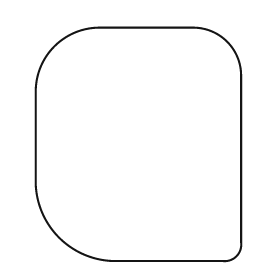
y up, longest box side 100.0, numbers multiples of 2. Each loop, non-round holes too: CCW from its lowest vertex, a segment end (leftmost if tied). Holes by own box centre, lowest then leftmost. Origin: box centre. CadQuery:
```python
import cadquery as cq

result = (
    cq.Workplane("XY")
    .moveTo(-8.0, -50.0)
    .lineTo(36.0, -50.0)
    .threePointArc((42.0, -48.0), (44.0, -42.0))
    .lineTo(44.0, 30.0)
    .threePointArc((38.0, 44.0), (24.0, 50.0))
    .lineTo(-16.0, 50.0)
    .threePointArc((-36.0, 42.0), (-44.0, 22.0))
    .lineTo(-44.0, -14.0)
    .threePointArc((-34.0, -40.0), (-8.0, -50.0))
    .close()
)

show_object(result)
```